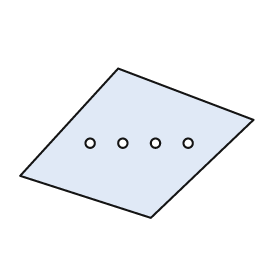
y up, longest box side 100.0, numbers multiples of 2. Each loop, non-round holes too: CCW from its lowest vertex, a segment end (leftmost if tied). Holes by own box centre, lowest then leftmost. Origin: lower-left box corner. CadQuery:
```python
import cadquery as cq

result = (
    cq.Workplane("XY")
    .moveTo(56.0, 0.0)
    .lineTo(100.0, 42.0)
    .lineTo(42.0, 64.0)
    .lineTo(0.0, 18.0)
    .close()
    .moveTo(30.0, 32.0)
    .circle(2.0)
    .moveTo(44.0, 32.0)
    .circle(2.0)
    .moveTo(58.0, 32.0)
    .circle(2.0)
    .moveTo(72.0, 32.0)
    .circle(2.0)
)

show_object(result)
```